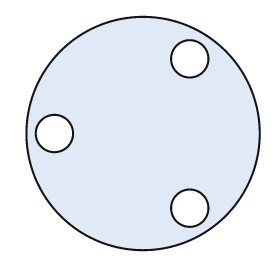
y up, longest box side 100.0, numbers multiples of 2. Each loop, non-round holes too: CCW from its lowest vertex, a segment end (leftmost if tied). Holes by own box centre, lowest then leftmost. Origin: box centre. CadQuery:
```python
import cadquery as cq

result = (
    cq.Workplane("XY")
    .moveTo(0.0, 0.0)
    .circle(50.0)
    .moveTo(20.0, -32.0)
    .circle(8.0)
    .moveTo(-38.0, 0.0)
    .circle(8.0)
    .moveTo(20.0, 32.0)
    .circle(8.0)
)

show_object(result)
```